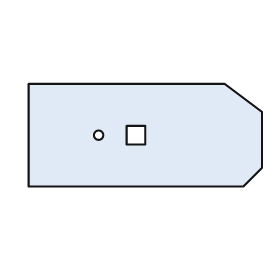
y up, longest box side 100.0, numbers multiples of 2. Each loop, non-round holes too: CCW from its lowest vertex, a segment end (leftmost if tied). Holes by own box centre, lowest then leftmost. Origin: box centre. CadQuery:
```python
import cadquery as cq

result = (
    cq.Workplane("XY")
    .moveTo(-50.0, -22.0)
    .lineTo(42.0, -22.0)
    .lineTo(50.0, -14.0)
    .lineTo(50.0, 10.0)
    .lineTo(34.0, 22.0)
    .lineTo(-50.0, 22.0)
    .close()
    .moveTo(-20.0, 0.0)
    .circle(2.0)
    .moveTo(-8.0, -4.0)
    .lineTo(0.0, -4.0)
    .lineTo(0.0, 4.0)
    .lineTo(-8.0, 4.0)
    .close()
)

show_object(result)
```